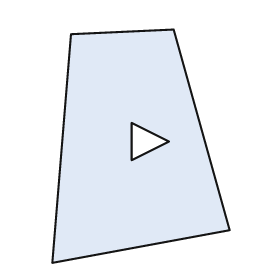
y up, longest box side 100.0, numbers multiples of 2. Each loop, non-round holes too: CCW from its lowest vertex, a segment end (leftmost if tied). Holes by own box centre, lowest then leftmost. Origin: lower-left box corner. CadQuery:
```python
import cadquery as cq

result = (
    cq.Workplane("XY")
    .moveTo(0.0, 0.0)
    .lineTo(76.0, 14.0)
    .lineTo(52.0, 100.0)
    .lineTo(8.0, 98.0)
    .close()
    .moveTo(34.0, 44.0)
    .lineTo(50.0, 52.0)
    .lineTo(34.0, 60.0)
    .close()
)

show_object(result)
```